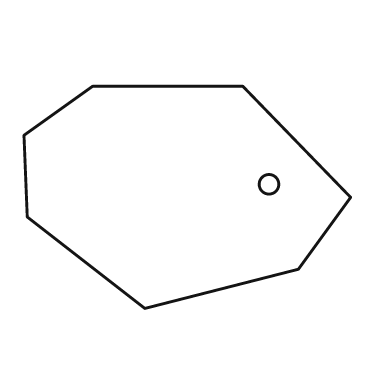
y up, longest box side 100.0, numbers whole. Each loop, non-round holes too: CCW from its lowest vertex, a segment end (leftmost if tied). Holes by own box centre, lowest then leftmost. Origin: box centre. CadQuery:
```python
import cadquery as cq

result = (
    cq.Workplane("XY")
    .moveTo(-13.0, -34.0)
    .lineTo(34.0, -22.0)
    .lineTo(50.0, 0.0)
    .lineTo(17.0, 34.0)
    .lineTo(-29.0, 34.0)
    .lineTo(-50.0, 19.0)
    .lineTo(-49.0, -6.0)
    .close()
    .moveTo(25.0, 4.0)
    .circle(3.0)
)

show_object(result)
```